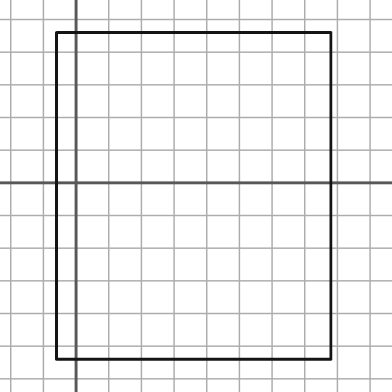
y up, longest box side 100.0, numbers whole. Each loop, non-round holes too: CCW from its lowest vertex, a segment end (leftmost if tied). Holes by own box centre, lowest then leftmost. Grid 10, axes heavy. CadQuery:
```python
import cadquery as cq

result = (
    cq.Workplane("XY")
    .moveTo(-6.0, -54.0)
    .lineTo(78.0, -54.0)
    .lineTo(78.0, 46.0)
    .lineTo(-6.0, 46.0)
    .close()
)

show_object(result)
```